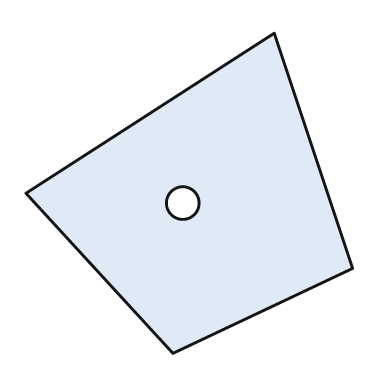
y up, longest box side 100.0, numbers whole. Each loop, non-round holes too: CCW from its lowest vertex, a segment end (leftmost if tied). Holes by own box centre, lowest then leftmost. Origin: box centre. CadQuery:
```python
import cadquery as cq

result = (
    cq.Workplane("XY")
    .moveTo(-5.0, -49.0)
    .lineTo(50.0, -23.0)
    .lineTo(26.0, 49.0)
    .lineTo(-50.0, 0.0)
    .close()
    .moveTo(-2.0, -3.0)
    .circle(5.0)
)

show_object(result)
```